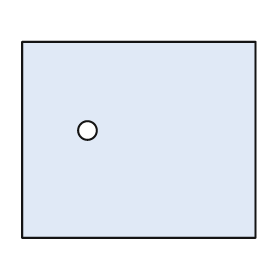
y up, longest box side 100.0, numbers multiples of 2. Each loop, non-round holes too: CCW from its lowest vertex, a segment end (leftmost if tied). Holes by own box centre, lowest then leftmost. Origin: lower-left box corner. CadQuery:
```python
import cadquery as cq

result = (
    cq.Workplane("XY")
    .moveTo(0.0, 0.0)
    .lineTo(100.0, 0.0)
    .lineTo(100.0, 84.0)
    .lineTo(0.0, 84.0)
    .close()
    .moveTo(28.0, 46.0)
    .circle(4.0)
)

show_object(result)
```